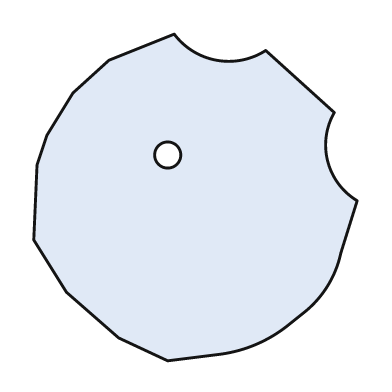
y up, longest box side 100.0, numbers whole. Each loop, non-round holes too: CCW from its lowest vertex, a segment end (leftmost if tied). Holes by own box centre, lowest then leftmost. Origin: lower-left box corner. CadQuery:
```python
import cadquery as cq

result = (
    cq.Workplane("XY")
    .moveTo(41.0, 0.0)
    .lineTo(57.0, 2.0)
    .threePointArc((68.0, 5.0), (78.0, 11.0))
    .lineTo(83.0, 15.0)
    .threePointArc((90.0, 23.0), (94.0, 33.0))
    .lineTo(99.0, 49.0)
    .threePointArc((90.0, 61.0), (92.0, 76.0))
    .lineTo(71.0, 95.0)
    .threePointArc((56.0, 92.0), (43.0, 100.0))
    .lineTo(23.0, 92.0)
    .lineTo(12.0, 82.0)
    .lineTo(4.0, 69.0)
    .lineTo(1.0, 60.0)
    .lineTo(0.0, 37.0)
    .lineTo(10.0, 21.0)
    .lineTo(26.0, 7.0)
    .close()
    .moveTo(41.0, 63.0)
    .circle(4.0)
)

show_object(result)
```